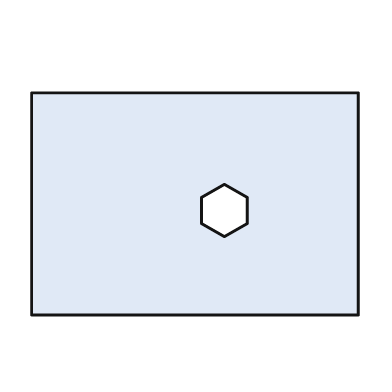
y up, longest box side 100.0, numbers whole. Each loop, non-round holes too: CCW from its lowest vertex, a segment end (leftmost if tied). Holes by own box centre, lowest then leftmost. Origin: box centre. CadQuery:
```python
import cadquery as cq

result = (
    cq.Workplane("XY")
    .moveTo(-50.0, -34.0)
    .lineTo(50.0, -34.0)
    .lineTo(50.0, 34.0)
    .lineTo(-50.0, 34.0)
    .close()
    .moveTo(9.0, -10.0)
    .lineTo(16.0, -6.0)
    .lineTo(16.0, 2.0)
    .lineTo(9.0, 6.0)
    .lineTo(2.0, 2.0)
    .lineTo(2.0, -6.0)
    .close()
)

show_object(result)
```